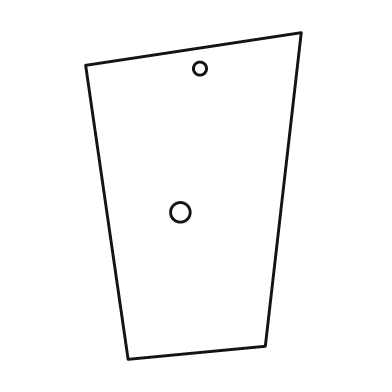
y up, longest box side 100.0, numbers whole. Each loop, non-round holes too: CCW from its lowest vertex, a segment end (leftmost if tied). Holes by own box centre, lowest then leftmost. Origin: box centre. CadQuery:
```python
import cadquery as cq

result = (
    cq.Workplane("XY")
    .moveTo(-20.0, -50.0)
    .lineTo(22.0, -46.0)
    .lineTo(33.0, 50.0)
    .lineTo(-33.0, 40.0)
    .close()
    .moveTo(-4.0, -5.0)
    .circle(3.0)
    .moveTo(2.0, 39.0)
    .circle(2.0)
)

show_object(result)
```